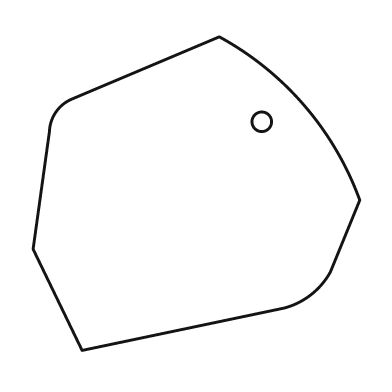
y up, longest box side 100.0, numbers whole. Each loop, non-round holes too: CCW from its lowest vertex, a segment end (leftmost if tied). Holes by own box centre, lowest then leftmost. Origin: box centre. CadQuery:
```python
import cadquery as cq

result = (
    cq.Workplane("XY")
    .moveTo(-35.0, -48.0)
    .lineTo(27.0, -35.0)
    .threePointArc((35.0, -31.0), (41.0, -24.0))
    .lineTo(50.0, -2.0)
    .threePointArc((33.0, 27.0), (7.0, 48.0))
    .lineTo(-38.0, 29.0)
    .threePointArc((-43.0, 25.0), (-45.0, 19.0))
    .lineTo(-50.0, -17.0)
    .close()
    .moveTo(20.0, 22.0)
    .circle(3.0)
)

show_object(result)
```